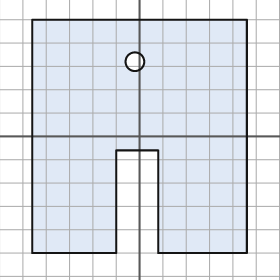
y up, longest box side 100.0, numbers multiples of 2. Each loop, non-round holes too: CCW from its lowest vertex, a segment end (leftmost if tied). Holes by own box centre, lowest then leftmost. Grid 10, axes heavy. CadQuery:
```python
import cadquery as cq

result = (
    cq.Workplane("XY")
    .moveTo(-46.0, -50.0)
    .lineTo(-10.0, -50.0)
    .lineTo(-10.0, -6.0)
    .lineTo(8.0, -6.0)
    .lineTo(8.0, -50.0)
    .lineTo(46.0, -50.0)
    .lineTo(46.0, 50.0)
    .lineTo(-46.0, 50.0)
    .close()
    .moveTo(-2.0, 32.0)
    .circle(4.0)
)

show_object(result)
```